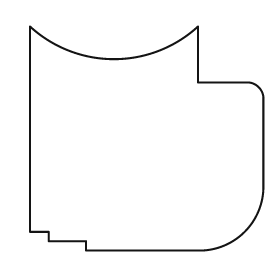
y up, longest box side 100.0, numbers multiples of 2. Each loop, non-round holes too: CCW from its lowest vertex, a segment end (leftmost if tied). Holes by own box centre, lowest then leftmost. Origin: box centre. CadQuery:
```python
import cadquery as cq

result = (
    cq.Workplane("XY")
    .moveTo(-26.0, -48.0)
    .lineTo(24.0, -48.0)
    .threePointArc((42.0, -40.0), (50.0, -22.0))
    .lineTo(50.0, 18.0)
    .threePointArc((48.0, 22.0), (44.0, 24.0))
    .lineTo(22.0, 24.0)
    .lineTo(22.0, 48.0)
    .threePointArc((-14.0, 34.0), (-50.0, 48.0))
    .lineTo(-50.0, -40.0)
    .lineTo(-42.0, -40.0)
    .lineTo(-42.0, -44.0)
    .lineTo(-26.0, -44.0)
    .close()
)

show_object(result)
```